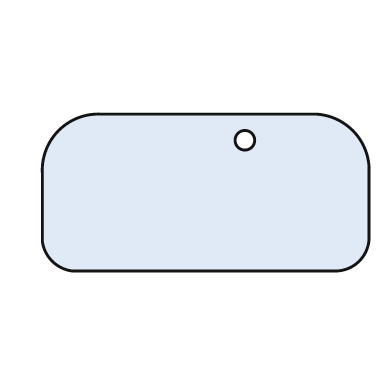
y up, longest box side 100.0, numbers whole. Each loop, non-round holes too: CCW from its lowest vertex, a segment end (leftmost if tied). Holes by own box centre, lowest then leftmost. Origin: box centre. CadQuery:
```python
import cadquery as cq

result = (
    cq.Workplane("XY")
    .moveTo(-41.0, -24.0)
    .lineTo(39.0, -24.0)
    .threePointArc((47.0, -21.0), (50.0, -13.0))
    .lineTo(50.0, 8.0)
    .threePointArc((45.0, 19.0), (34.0, 24.0))
    .lineTo(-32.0, 24.0)
    .threePointArc((-45.0, 19.0), (-50.0, 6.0))
    .lineTo(-50.0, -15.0)
    .threePointArc((-47.0, -21.0), (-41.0, -24.0))
    .close()
    .moveTo(12.0, 16.0)
    .circle(3.0)
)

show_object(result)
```